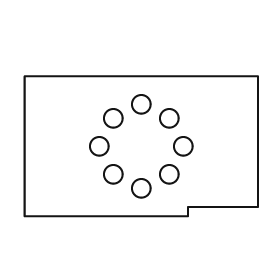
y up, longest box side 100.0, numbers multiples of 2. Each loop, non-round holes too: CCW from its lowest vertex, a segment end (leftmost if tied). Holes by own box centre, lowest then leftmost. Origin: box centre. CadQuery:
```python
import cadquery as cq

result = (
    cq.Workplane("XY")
    .moveTo(-50.0, -30.0)
    .lineTo(20.0, -30.0)
    .lineTo(20.0, -26.0)
    .lineTo(50.0, -26.0)
    .lineTo(50.0, 30.0)
    .lineTo(-50.0, 30.0)
    .close()
    .moveTo(0.0, -18.0)
    .circle(4.0)
    .moveTo(-12.0, -12.0)
    .circle(4.0)
    .moveTo(12.0, -12.0)
    .circle(4.0)
    .moveTo(-18.0, 0.0)
    .circle(4.0)
    .moveTo(18.0, 0.0)
    .circle(4.0)
    .moveTo(-12.0, 12.0)
    .circle(4.0)
    .moveTo(12.0, 12.0)
    .circle(4.0)
    .moveTo(0.0, 18.0)
    .circle(4.0)
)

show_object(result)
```